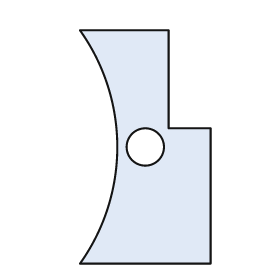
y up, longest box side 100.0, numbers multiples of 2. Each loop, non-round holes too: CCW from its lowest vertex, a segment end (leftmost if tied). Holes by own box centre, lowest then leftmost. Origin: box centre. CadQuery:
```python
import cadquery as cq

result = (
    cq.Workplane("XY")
    .moveTo(-28.0, -50.0)
    .lineTo(28.0, -50.0)
    .lineTo(28.0, 8.0)
    .lineTo(10.0, 8.0)
    .lineTo(10.0, 50.0)
    .lineTo(-28.0, 50.0)
    .threePointArc((-12.0, 0.0), (-28.0, -50.0))
    .close()
    .moveTo(0.0, 0.0)
    .circle(8.0)
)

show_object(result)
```